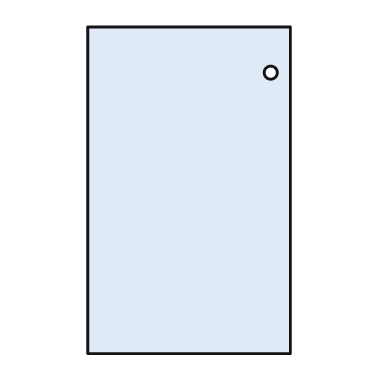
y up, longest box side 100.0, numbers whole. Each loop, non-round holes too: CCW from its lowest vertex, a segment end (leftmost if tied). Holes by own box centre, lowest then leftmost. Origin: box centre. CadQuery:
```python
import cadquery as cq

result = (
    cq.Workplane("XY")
    .moveTo(-31.0, -50.0)
    .lineTo(31.0, -50.0)
    .lineTo(31.0, 50.0)
    .lineTo(-31.0, 50.0)
    .close()
    .moveTo(25.0, 36.0)
    .circle(2.0)
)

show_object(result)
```